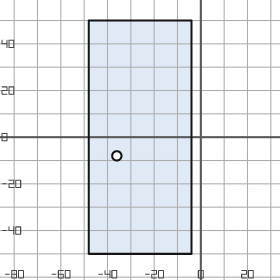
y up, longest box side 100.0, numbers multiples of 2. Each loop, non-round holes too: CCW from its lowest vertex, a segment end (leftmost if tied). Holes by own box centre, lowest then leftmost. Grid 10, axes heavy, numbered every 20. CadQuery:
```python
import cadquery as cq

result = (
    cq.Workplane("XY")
    .moveTo(-48.0, -50.0)
    .lineTo(-4.0, -50.0)
    .lineTo(-4.0, 50.0)
    .lineTo(-48.0, 50.0)
    .close()
    .moveTo(-36.0, -8.0)
    .circle(2.0)
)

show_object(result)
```